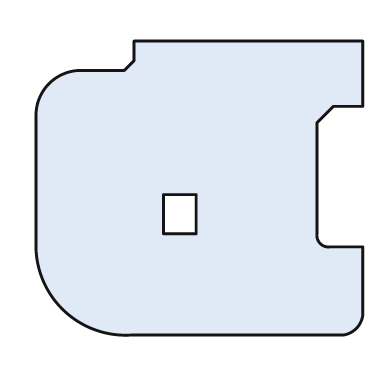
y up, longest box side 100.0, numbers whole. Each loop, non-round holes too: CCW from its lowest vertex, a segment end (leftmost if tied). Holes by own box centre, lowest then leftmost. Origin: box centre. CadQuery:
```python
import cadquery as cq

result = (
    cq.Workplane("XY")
    .moveTo(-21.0, -45.0)
    .lineTo(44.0, -45.0)
    .threePointArc((48.0, -43.0), (50.0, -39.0))
    .lineTo(50.0, -18.0)
    .lineTo(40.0, -18.0)
    .threePointArc((37.0, -17.0), (36.0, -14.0))
    .lineTo(36.0, 20.0)
    .lineTo(41.0, 25.0)
    .lineTo(50.0, 25.0)
    .lineTo(50.0, 45.0)
    .lineTo(-20.0, 45.0)
    .lineTo(-20.0, 39.0)
    .lineTo(-23.0, 36.0)
    .lineTo(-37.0, 36.0)
    .threePointArc((-46.0, 32.0), (-50.0, 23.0))
    .lineTo(-50.0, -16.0)
    .threePointArc((-42.0, -37.0), (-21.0, -45.0))
    .close()
    .moveTo(-11.0, -14.0)
    .lineTo(-1.0, -14.0)
    .lineTo(-1.0, -2.0)
    .lineTo(-11.0, -2.0)
    .close()
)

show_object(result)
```